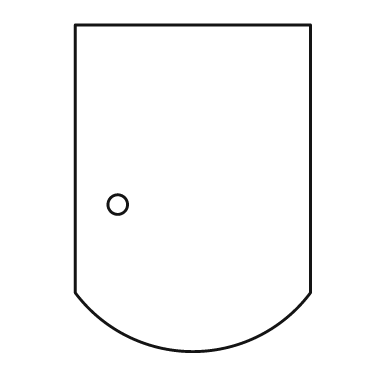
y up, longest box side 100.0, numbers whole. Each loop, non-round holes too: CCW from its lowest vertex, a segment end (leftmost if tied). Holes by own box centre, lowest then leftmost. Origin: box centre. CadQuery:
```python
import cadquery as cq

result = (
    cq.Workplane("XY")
    .moveTo(-36.0, -32.0)
    .threePointArc((0.0, -50.0), (36.0, -32.0))
    .lineTo(36.0, 50.0)
    .lineTo(-36.0, 50.0)
    .close()
    .moveTo(-23.0, -5.0)
    .circle(3.0)
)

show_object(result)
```